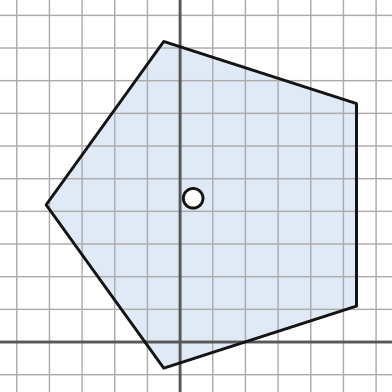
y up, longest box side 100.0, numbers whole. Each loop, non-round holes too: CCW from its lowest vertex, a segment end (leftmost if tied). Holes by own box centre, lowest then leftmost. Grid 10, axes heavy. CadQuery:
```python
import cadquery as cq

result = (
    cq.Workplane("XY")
    .moveTo(-5.0, -8.0)
    .lineTo(54.0, 11.0)
    .lineTo(54.0, 73.0)
    .lineTo(-5.0, 92.0)
    .lineTo(-41.0, 42.0)
    .close()
    .moveTo(4.0, 44.0)
    .circle(3.0)
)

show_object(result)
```